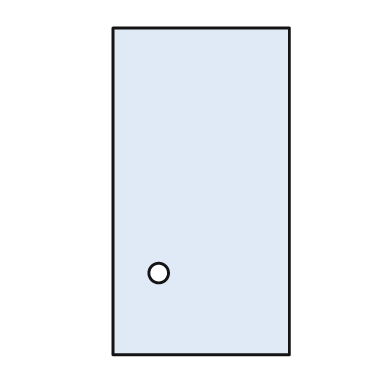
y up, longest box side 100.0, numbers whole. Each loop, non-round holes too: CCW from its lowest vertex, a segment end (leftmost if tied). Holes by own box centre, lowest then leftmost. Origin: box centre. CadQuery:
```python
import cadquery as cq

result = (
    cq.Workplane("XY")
    .moveTo(-27.0, -50.0)
    .lineTo(27.0, -50.0)
    .lineTo(27.0, 50.0)
    .lineTo(-27.0, 50.0)
    .close()
    .moveTo(-13.0, -25.0)
    .circle(3.0)
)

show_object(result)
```